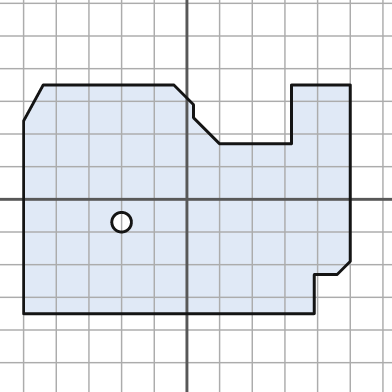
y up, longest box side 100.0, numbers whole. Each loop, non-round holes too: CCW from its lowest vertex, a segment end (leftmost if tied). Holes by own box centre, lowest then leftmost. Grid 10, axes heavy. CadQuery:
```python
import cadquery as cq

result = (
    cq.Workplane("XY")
    .moveTo(-50.0, -35.0)
    .lineTo(39.0, -35.0)
    .lineTo(39.0, -23.0)
    .lineTo(46.0, -23.0)
    .lineTo(50.0, -19.0)
    .lineTo(50.0, 35.0)
    .lineTo(32.0, 35.0)
    .lineTo(32.0, 17.0)
    .lineTo(10.0, 17.0)
    .lineTo(2.0, 25.0)
    .lineTo(2.0, 29.0)
    .lineTo(-4.0, 35.0)
    .lineTo(-44.0, 35.0)
    .lineTo(-50.0, 24.0)
    .close()
    .moveTo(-20.0, -7.0)
    .circle(3.0)
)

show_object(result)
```